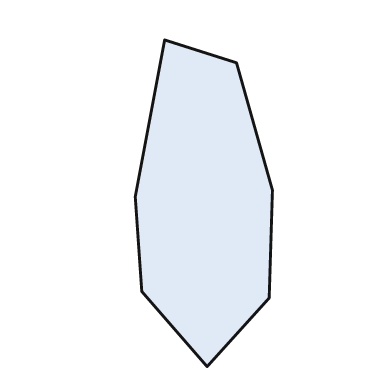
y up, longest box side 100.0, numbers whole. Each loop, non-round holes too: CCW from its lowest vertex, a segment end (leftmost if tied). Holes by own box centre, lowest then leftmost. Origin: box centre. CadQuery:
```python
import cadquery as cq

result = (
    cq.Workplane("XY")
    .moveTo(1.0, -50.0)
    .lineTo(20.0, -29.0)
    .lineTo(21.0, 4.0)
    .lineTo(10.0, 43.0)
    .lineTo(-12.0, 50.0)
    .lineTo(-21.0, 2.0)
    .lineTo(-19.0, -27.0)
    .close()
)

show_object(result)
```